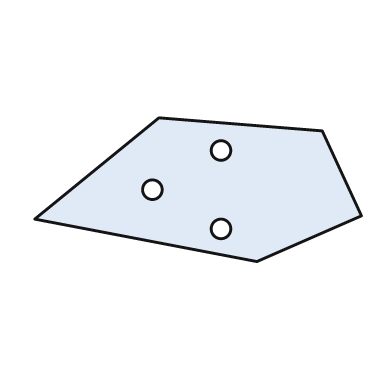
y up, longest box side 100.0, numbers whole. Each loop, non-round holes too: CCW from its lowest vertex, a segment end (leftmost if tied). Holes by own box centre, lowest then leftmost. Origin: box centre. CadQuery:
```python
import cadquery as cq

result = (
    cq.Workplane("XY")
    .moveTo(18.0, -22.0)
    .lineTo(50.0, -8.0)
    .lineTo(38.0, 18.0)
    .lineTo(-12.0, 22.0)
    .lineTo(-50.0, -9.0)
    .close()
    .moveTo(7.0, -12.0)
    .circle(3.0)
    .moveTo(-14.0, 0.0)
    .circle(3.0)
    .moveTo(7.0, 12.0)
    .circle(3.0)
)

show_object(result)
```